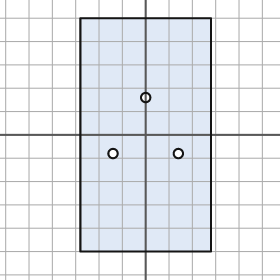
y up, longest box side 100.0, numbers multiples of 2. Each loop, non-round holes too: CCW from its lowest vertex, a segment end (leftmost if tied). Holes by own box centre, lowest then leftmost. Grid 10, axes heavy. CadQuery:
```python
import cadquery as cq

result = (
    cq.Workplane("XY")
    .moveTo(-28.0, -50.0)
    .lineTo(28.0, -50.0)
    .lineTo(28.0, 50.0)
    .lineTo(-28.0, 50.0)
    .close()
    .moveTo(-14.0, -8.0)
    .circle(2.0)
    .moveTo(14.0, -8.0)
    .circle(2.0)
    .moveTo(0.0, 16.0)
    .circle(2.0)
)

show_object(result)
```